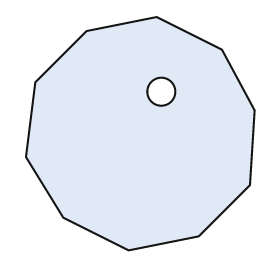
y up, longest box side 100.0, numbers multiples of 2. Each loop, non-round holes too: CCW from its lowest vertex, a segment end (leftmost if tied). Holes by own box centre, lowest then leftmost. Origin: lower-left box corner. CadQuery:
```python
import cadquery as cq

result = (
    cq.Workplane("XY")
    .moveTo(44.0, 0.0)
    .lineTo(74.0, 6.0)
    .lineTo(96.0, 28.0)
    .lineTo(98.0, 60.0)
    .lineTo(84.0, 86.0)
    .lineTo(56.0, 100.0)
    .lineTo(26.0, 94.0)
    .lineTo(4.0, 72.0)
    .lineTo(0.0, 40.0)
    .lineTo(16.0, 14.0)
    .close()
    .moveTo(58.0, 68.0)
    .circle(6.0)
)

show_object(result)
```